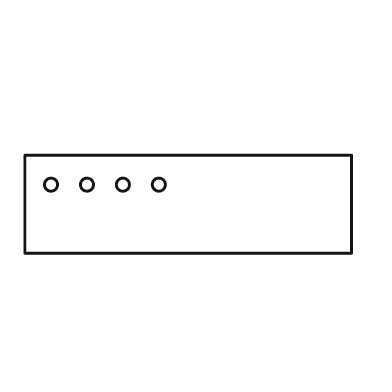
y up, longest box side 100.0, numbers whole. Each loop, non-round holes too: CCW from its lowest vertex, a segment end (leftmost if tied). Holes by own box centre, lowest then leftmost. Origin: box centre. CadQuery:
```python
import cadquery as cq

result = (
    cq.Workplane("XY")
    .moveTo(-50.0, -15.0)
    .lineTo(50.0, -15.0)
    .lineTo(50.0, 15.0)
    .lineTo(-50.0, 15.0)
    .close()
    .moveTo(-42.0, 6.0)
    .circle(2.0)
    .moveTo(-31.0, 6.0)
    .circle(2.0)
    .moveTo(-20.0, 6.0)
    .circle(2.0)
    .moveTo(-9.0, 6.0)
    .circle(2.0)
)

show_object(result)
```